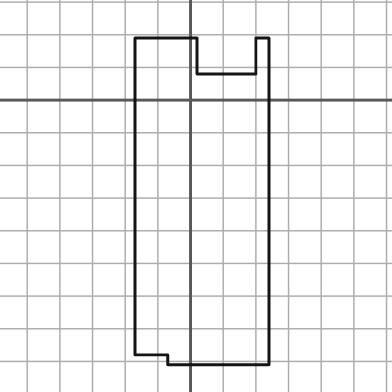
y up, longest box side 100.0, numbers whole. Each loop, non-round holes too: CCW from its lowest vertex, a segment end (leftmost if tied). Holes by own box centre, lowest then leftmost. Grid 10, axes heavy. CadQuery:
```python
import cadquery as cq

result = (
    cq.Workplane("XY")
    .moveTo(-7.0, -81.0)
    .lineTo(24.0, -81.0)
    .lineTo(24.0, 19.0)
    .lineTo(20.0, 19.0)
    .lineTo(20.0, 8.0)
    .lineTo(2.0, 8.0)
    .lineTo(2.0, 19.0)
    .lineTo(-17.0, 19.0)
    .lineTo(-17.0, -78.0)
    .lineTo(-7.0, -78.0)
    .close()
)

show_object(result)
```